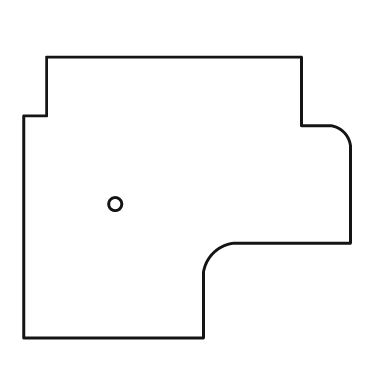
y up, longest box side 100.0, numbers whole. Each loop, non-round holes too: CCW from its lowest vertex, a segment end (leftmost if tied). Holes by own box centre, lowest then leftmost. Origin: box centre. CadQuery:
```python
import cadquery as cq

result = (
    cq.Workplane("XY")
    .moveTo(-50.0, -43.0)
    .lineTo(5.0, -43.0)
    .lineTo(5.0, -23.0)
    .threePointArc((8.0, -17.0), (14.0, -14.0))
    .lineTo(50.0, -14.0)
    .lineTo(50.0, 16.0)
    .threePointArc((48.0, 20.0), (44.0, 22.0))
    .lineTo(35.0, 22.0)
    .lineTo(35.0, 43.0)
    .lineTo(-43.0, 43.0)
    .lineTo(-43.0, 25.0)
    .lineTo(-50.0, 25.0)
    .close()
    .moveTo(-22.0, -2.0)
    .circle(2.0)
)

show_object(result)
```